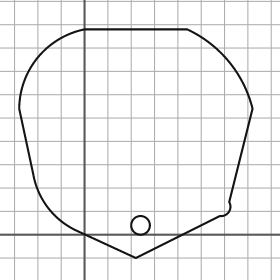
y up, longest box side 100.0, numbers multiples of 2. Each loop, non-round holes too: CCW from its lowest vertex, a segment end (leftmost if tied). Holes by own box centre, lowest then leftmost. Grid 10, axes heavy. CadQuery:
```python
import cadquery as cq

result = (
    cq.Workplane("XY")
    .moveTo(22.0, -10.0)
    .lineTo(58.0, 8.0)
    .threePointArc((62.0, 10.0), (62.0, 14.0))
    .lineTo(72.0, 54.0)
    .threePointArc((62.0, 74.0), (44.0, 88.0))
    .lineTo(0.0, 88.0)
    .threePointArc((-20.0, 76.0), (-28.0, 54.0))
    .lineTo(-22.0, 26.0)
    .threePointArc((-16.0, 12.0), (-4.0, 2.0))
    .close()
    .moveTo(24.0, 4.0)
    .circle(4.0)
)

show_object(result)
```